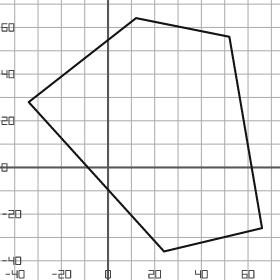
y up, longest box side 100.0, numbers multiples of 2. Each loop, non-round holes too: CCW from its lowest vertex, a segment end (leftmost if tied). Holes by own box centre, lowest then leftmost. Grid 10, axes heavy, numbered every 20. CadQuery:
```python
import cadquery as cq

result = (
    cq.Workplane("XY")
    .moveTo(24.0, -36.0)
    .lineTo(66.0, -26.0)
    .lineTo(52.0, 56.0)
    .lineTo(12.0, 64.0)
    .lineTo(-34.0, 28.0)
    .close()
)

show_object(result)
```